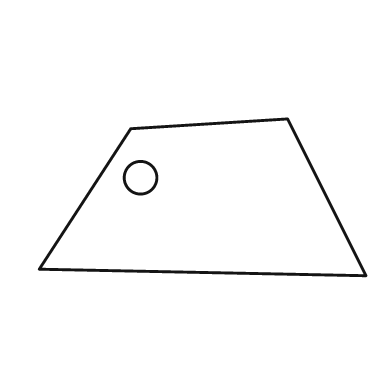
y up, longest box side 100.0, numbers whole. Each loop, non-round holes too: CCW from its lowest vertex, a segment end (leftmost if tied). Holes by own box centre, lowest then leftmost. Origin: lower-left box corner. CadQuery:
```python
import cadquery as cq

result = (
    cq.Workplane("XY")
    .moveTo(100.0, 0.0)
    .lineTo(76.0, 48.0)
    .lineTo(28.0, 45.0)
    .lineTo(0.0, 2.0)
    .close()
    .moveTo(31.0, 30.0)
    .circle(5.0)
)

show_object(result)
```